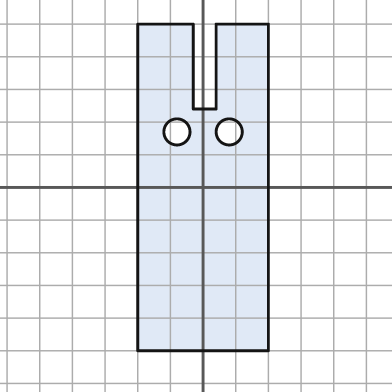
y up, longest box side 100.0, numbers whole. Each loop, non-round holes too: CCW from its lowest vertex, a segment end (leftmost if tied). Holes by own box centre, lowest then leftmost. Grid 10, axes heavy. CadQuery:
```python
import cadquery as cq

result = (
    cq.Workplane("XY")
    .moveTo(-20.0, -50.0)
    .lineTo(20.0, -50.0)
    .lineTo(20.0, 50.0)
    .lineTo(4.0, 50.0)
    .lineTo(4.0, 24.0)
    .lineTo(-3.0, 24.0)
    .lineTo(-3.0, 50.0)
    .lineTo(-20.0, 50.0)
    .close()
    .moveTo(-8.0, 17.0)
    .circle(4.0)
    .moveTo(8.0, 17.0)
    .circle(4.0)
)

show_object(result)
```